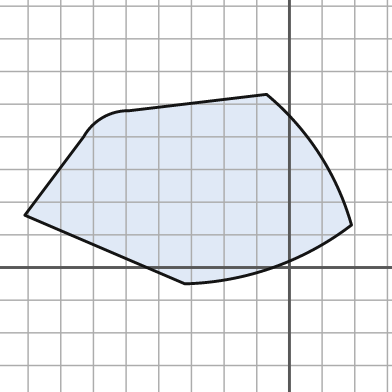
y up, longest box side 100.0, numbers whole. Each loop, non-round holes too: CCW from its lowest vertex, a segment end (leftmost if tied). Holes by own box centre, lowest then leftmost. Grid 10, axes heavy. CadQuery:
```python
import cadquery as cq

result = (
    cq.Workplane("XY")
    .moveTo(-32.0, -5.0)
    .threePointArc((-5.0, 0.0), (19.0, 13.0))
    .threePointArc((9.0, 35.0), (-7.0, 53.0))
    .lineTo(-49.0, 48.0)
    .threePointArc((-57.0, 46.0), (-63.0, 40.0))
    .lineTo(-81.0, 16.0)
    .close()
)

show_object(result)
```